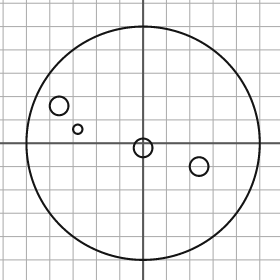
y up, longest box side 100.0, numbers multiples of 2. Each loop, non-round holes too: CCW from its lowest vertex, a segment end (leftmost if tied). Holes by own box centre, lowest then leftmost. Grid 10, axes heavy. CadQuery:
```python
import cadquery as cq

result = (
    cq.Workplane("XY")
    .moveTo(0.0, 0.0)
    .circle(50.0)
    .moveTo(24.0, -10.0)
    .circle(4.0)
    .moveTo(0.0, -2.0)
    .circle(4.0)
    .moveTo(-28.0, 6.0)
    .circle(2.0)
    .moveTo(-36.0, 16.0)
    .circle(4.0)
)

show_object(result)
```